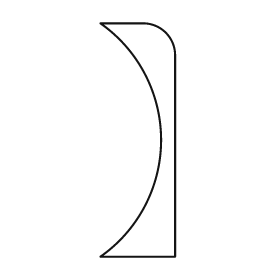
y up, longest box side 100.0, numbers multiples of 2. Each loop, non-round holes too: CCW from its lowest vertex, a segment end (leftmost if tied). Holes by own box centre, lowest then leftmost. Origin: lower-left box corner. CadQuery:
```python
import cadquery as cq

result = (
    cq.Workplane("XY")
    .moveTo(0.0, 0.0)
    .lineTo(32.0, 0.0)
    .lineTo(32.0, 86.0)
    .threePointArc((28.0, 96.0), (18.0, 100.0))
    .lineTo(0.0, 100.0)
    .threePointArc((26.0, 50.0), (0.0, 0.0))
    .close()
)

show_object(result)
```